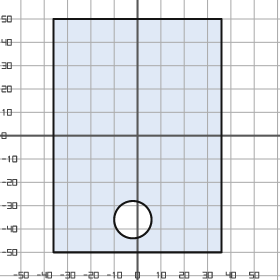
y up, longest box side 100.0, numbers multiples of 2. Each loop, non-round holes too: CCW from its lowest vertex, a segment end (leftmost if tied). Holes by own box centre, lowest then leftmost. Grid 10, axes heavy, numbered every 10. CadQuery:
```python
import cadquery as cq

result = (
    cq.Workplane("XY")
    .moveTo(-36.0, -50.0)
    .lineTo(36.0, -50.0)
    .lineTo(36.0, 50.0)
    .lineTo(-36.0, 50.0)
    .close()
    .moveTo(-2.0, -36.0)
    .circle(8.0)
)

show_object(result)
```